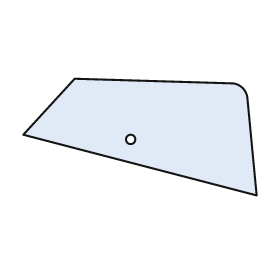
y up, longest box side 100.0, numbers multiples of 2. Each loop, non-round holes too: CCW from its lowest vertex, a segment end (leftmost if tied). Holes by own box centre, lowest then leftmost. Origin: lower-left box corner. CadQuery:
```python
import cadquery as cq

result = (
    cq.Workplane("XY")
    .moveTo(100.0, 0.0)
    .lineTo(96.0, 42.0)
    .threePointArc((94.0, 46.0), (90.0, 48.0))
    .lineTo(22.0, 50.0)
    .lineTo(0.0, 26.0)
    .close()
    .moveTo(46.0, 24.0)
    .circle(2.0)
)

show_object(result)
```